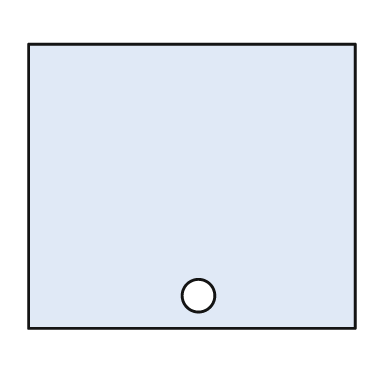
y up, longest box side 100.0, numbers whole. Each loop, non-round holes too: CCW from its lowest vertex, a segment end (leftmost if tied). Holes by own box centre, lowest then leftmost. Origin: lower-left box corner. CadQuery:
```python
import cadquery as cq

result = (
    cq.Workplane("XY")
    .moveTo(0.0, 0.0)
    .lineTo(100.0, 0.0)
    .lineTo(100.0, 87.0)
    .lineTo(0.0, 87.0)
    .close()
    .moveTo(52.0, 10.0)
    .circle(5.0)
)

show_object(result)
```